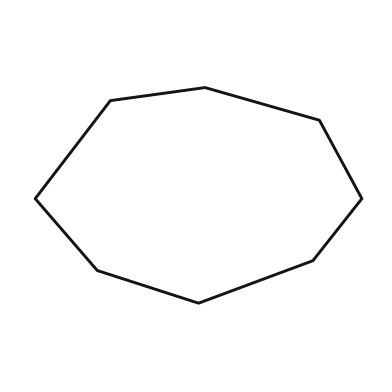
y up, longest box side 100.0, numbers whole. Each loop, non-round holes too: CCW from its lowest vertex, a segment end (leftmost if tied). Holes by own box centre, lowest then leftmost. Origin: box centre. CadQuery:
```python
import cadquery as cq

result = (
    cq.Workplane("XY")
    .moveTo(0.0, -33.0)
    .lineTo(35.0, -20.0)
    .lineTo(50.0, -1.0)
    .lineTo(37.0, 23.0)
    .lineTo(2.0, 33.0)
    .lineTo(-27.0, 29.0)
    .lineTo(-50.0, -1.0)
    .lineTo(-31.0, -23.0)
    .close()
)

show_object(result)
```